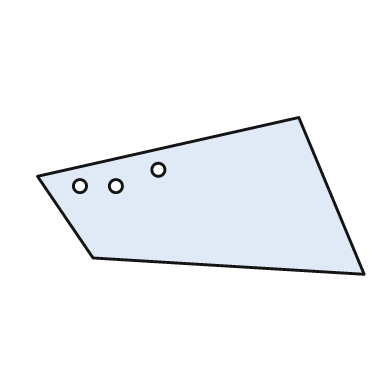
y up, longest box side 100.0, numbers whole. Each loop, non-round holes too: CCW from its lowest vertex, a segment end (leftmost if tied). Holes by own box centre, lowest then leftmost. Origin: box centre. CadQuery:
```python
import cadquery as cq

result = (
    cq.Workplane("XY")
    .moveTo(50.0, -24.0)
    .lineTo(30.0, 24.0)
    .lineTo(-50.0, 6.0)
    .lineTo(-33.0, -19.0)
    .close()
    .moveTo(-37.0, 3.0)
    .circle(2.0)
    .moveTo(-26.0, 3.0)
    .circle(2.0)
    .moveTo(-13.0, 8.0)
    .circle(2.0)
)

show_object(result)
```